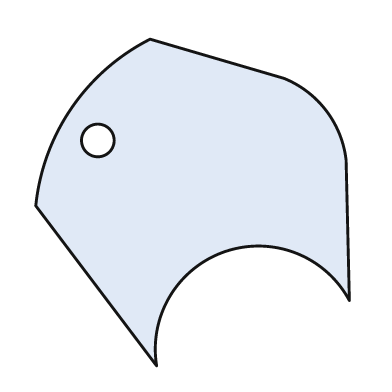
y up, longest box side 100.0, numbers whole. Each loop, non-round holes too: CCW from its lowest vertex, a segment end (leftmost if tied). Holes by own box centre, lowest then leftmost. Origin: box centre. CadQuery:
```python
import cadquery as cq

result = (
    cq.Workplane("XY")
    .moveTo(-11.0, -50.0)
    .threePointArc((10.0, -15.0), (48.0, -30.0))
    .lineTo(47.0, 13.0)
    .threePointArc((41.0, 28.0), (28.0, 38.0))
    .lineTo(-13.0, 50.0)
    .threePointArc((-37.0, 29.0), (-48.0, -1.0))
    .close()
    .moveTo(-29.0, 19.0)
    .circle(5.0)
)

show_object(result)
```